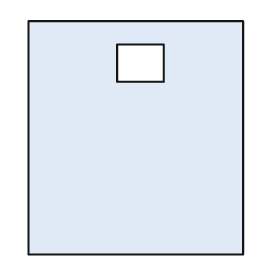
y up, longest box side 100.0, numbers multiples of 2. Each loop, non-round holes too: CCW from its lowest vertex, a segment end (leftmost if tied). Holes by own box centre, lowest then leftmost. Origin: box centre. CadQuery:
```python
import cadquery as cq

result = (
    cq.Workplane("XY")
    .moveTo(-46.0, -50.0)
    .lineTo(46.0, -50.0)
    .lineTo(46.0, 50.0)
    .lineTo(-46.0, 50.0)
    .close()
    .moveTo(-8.0, 24.0)
    .lineTo(12.0, 24.0)
    .lineTo(12.0, 40.0)
    .lineTo(-8.0, 40.0)
    .close()
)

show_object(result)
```